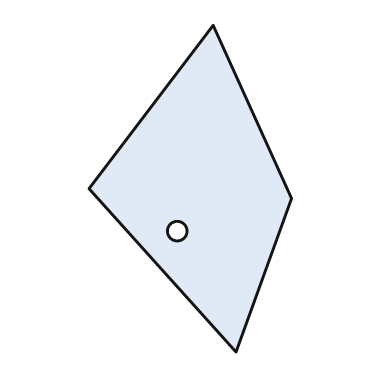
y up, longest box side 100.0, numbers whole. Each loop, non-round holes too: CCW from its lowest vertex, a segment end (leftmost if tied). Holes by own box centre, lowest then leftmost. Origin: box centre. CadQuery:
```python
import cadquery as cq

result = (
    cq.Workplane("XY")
    .moveTo(14.0, -50.0)
    .lineTo(31.0, -3.0)
    .lineTo(7.0, 50.0)
    .lineTo(-31.0, 0.0)
    .close()
    .moveTo(-4.0, -13.0)
    .circle(3.0)
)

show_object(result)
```